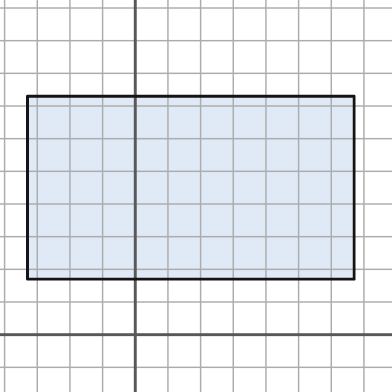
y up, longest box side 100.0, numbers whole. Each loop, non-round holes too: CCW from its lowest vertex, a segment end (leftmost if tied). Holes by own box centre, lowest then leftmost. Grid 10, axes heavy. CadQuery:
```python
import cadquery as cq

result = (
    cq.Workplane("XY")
    .moveTo(-33.0, 17.0)
    .lineTo(67.0, 17.0)
    .lineTo(67.0, 73.0)
    .lineTo(-33.0, 73.0)
    .close()
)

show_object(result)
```